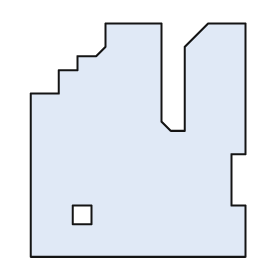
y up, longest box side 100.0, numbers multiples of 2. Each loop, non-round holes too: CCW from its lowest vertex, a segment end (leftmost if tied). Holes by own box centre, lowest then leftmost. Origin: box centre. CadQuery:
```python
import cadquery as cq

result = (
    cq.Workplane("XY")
    .moveTo(-46.0, -50.0)
    .lineTo(46.0, -50.0)
    .lineTo(46.0, -28.0)
    .lineTo(40.0, -28.0)
    .lineTo(40.0, -6.0)
    .lineTo(46.0, -6.0)
    .lineTo(46.0, 50.0)
    .lineTo(30.0, 50.0)
    .lineTo(20.0, 40.0)
    .lineTo(20.0, 4.0)
    .lineTo(14.0, 4.0)
    .lineTo(10.0, 8.0)
    .lineTo(10.0, 50.0)
    .lineTo(-14.0, 50.0)
    .lineTo(-14.0, 40.0)
    .lineTo(-18.0, 36.0)
    .lineTo(-26.0, 36.0)
    .lineTo(-26.0, 30.0)
    .lineTo(-34.0, 30.0)
    .lineTo(-34.0, 20.0)
    .lineTo(-46.0, 20.0)
    .close()
    .moveTo(-28.0, -36.0)
    .lineTo(-20.0, -36.0)
    .lineTo(-20.0, -28.0)
    .lineTo(-28.0, -28.0)
    .close()
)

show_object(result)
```